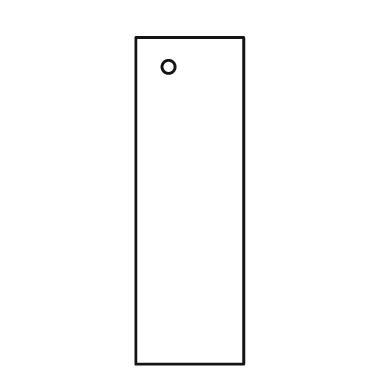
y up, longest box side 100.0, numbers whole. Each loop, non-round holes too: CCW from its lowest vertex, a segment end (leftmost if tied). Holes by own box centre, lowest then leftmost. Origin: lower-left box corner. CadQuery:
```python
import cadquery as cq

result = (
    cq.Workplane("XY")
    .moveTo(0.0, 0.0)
    .lineTo(33.0, 0.0)
    .lineTo(33.0, 100.0)
    .lineTo(0.0, 100.0)
    .close()
    .moveTo(10.0, 91.0)
    .circle(2.0)
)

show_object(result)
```